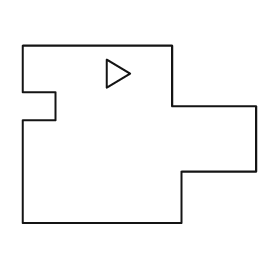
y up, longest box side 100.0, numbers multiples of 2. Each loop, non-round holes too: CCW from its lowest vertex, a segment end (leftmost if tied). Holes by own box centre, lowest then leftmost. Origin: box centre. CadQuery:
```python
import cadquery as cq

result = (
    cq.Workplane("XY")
    .moveTo(-50.0, -38.0)
    .lineTo(18.0, -38.0)
    .lineTo(18.0, -16.0)
    .lineTo(50.0, -16.0)
    .lineTo(50.0, 12.0)
    .lineTo(14.0, 12.0)
    .lineTo(14.0, 38.0)
    .lineTo(-50.0, 38.0)
    .lineTo(-50.0, 18.0)
    .lineTo(-36.0, 18.0)
    .lineTo(-36.0, 6.0)
    .lineTo(-50.0, 6.0)
    .close()
    .moveTo(-14.0, 20.0)
    .lineTo(-4.0, 26.0)
    .lineTo(-14.0, 32.0)
    .close()
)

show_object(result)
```